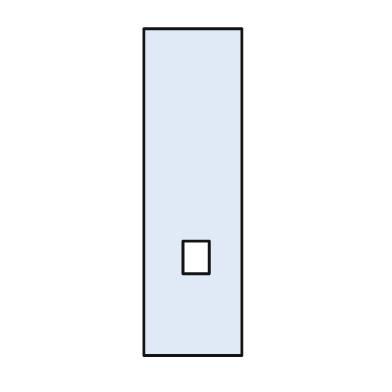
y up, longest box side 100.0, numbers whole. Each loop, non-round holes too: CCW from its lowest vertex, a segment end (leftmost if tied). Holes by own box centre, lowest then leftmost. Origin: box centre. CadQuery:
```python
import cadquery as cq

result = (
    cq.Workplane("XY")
    .moveTo(-15.0, -50.0)
    .lineTo(15.0, -50.0)
    .lineTo(15.0, 50.0)
    .lineTo(-15.0, 50.0)
    .close()
    .moveTo(-3.0, -25.0)
    .lineTo(5.0, -25.0)
    .lineTo(5.0, -15.0)
    .lineTo(-3.0, -15.0)
    .close()
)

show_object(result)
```